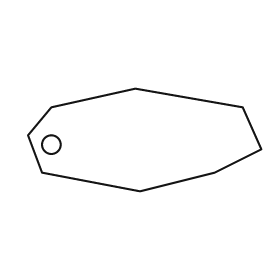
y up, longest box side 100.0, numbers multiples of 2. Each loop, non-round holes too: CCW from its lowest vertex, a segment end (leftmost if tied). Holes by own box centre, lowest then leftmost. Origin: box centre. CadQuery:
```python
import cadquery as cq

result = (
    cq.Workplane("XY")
    .moveTo(-2.0, -22.0)
    .lineTo(30.0, -14.0)
    .lineTo(50.0, -4.0)
    .lineTo(42.0, 14.0)
    .lineTo(-4.0, 22.0)
    .lineTo(-40.0, 14.0)
    .lineTo(-50.0, 2.0)
    .lineTo(-44.0, -14.0)
    .close()
    .moveTo(-40.0, -2.0)
    .circle(4.0)
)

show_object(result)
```